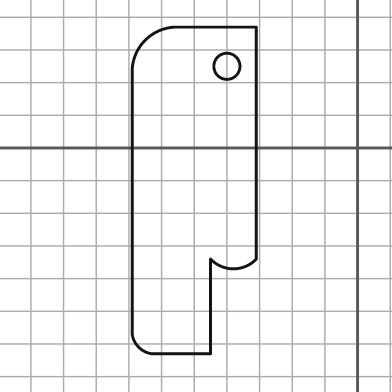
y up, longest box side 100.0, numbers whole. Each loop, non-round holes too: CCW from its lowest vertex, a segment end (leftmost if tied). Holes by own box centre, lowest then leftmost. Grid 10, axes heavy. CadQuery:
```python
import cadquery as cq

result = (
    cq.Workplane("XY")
    .moveTo(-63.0, -63.0)
    .lineTo(-45.0, -63.0)
    .lineTo(-45.0, -34.0)
    .threePointArc((-38.0, -37.0), (-31.0, -34.0))
    .lineTo(-31.0, 37.0)
    .lineTo(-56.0, 37.0)
    .threePointArc((-65.0, 33.0), (-69.0, 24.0))
    .lineTo(-69.0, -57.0)
    .threePointArc((-67.0, -61.0), (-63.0, -63.0))
    .close()
    .moveTo(-40.0, 25.0)
    .circle(4.0)
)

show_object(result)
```